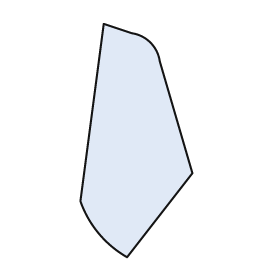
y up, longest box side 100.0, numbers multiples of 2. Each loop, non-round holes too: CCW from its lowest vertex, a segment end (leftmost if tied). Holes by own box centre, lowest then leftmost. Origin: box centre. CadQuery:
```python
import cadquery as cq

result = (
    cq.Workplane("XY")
    .moveTo(-4.0, -50.0)
    .lineTo(24.0, -14.0)
    .lineTo(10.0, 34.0)
    .threePointArc((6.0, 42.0), (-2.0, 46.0))
    .lineTo(-14.0, 50.0)
    .lineTo(-24.0, -26.0)
    .threePointArc((-16.0, -40.0), (-4.0, -50.0))
    .close()
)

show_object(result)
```